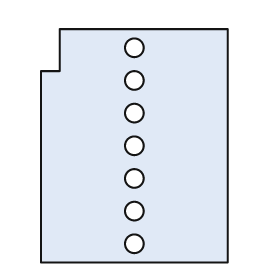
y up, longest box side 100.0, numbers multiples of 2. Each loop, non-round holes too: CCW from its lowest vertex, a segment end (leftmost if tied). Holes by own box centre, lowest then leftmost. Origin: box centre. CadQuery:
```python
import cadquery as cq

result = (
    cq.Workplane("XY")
    .moveTo(-40.0, -50.0)
    .lineTo(40.0, -50.0)
    .lineTo(40.0, 50.0)
    .lineTo(-32.0, 50.0)
    .lineTo(-32.0, 32.0)
    .lineTo(-40.0, 32.0)
    .close()
    .moveTo(0.0, -42.0)
    .circle(4.0)
    .moveTo(0.0, -28.0)
    .circle(4.0)
    .moveTo(0.0, -14.0)
    .circle(4.0)
    .moveTo(0.0, 0.0)
    .circle(4.0)
    .moveTo(0.0, 14.0)
    .circle(4.0)
    .moveTo(0.0, 28.0)
    .circle(4.0)
    .moveTo(0.0, 42.0)
    .circle(4.0)
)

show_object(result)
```